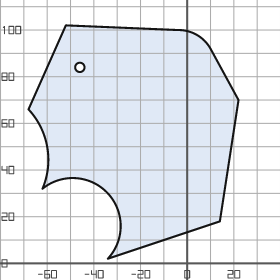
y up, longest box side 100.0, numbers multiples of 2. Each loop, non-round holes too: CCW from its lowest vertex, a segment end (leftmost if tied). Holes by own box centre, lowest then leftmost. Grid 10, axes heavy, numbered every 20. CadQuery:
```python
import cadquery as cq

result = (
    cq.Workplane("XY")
    .moveTo(-34.0, 2.0)
    .lineTo(14.0, 18.0)
    .lineTo(22.0, 70.0)
    .lineTo(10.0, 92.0)
    .threePointArc((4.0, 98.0), (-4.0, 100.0))
    .lineTo(-52.0, 102.0)
    .lineTo(-68.0, 66.0)
    .threePointArc((-60.0, 50.0), (-62.0, 32.0))
    .threePointArc((-34.0, 30.0), (-34.0, 2.0))
    .close()
    .moveTo(-46.0, 84.0)
    .circle(2.0)
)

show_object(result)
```